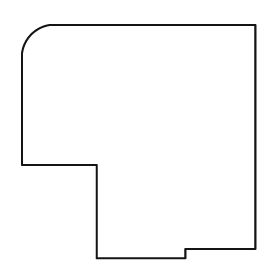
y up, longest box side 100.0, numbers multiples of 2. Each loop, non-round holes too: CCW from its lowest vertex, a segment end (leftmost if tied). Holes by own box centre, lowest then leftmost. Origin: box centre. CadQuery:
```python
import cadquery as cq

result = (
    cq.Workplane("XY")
    .moveTo(-18.0, -50.0)
    .lineTo(20.0, -50.0)
    .lineTo(20.0, -46.0)
    .lineTo(50.0, -46.0)
    .lineTo(50.0, 50.0)
    .lineTo(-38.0, 50.0)
    .threePointArc((-46.0, 46.0), (-50.0, 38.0))
    .lineTo(-50.0, -10.0)
    .lineTo(-18.0, -10.0)
    .close()
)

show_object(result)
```